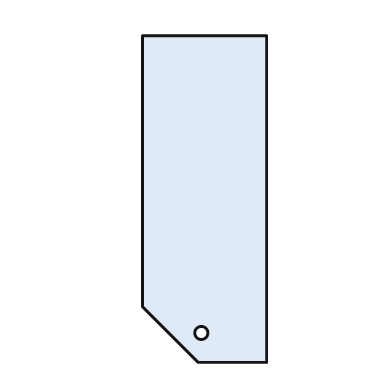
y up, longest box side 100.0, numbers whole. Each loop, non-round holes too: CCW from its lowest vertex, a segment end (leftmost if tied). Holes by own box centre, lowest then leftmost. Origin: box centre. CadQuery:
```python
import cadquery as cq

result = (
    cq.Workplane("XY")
    .moveTo(-2.0, -50.0)
    .lineTo(19.0, -50.0)
    .lineTo(19.0, 50.0)
    .lineTo(-19.0, 50.0)
    .lineTo(-19.0, -33.0)
    .close()
    .moveTo(-1.0, -41.0)
    .circle(2.0)
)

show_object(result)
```